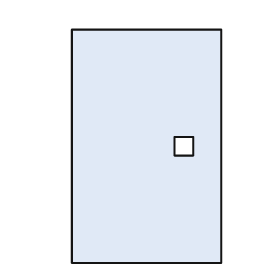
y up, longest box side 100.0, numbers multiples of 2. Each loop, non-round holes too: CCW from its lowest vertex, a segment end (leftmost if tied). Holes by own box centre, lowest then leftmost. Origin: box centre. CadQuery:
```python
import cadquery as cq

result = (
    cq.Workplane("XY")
    .moveTo(-32.0, -50.0)
    .lineTo(32.0, -50.0)
    .lineTo(32.0, 50.0)
    .lineTo(-32.0, 50.0)
    .close()
    .moveTo(12.0, -4.0)
    .lineTo(20.0, -4.0)
    .lineTo(20.0, 4.0)
    .lineTo(12.0, 4.0)
    .close()
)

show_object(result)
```